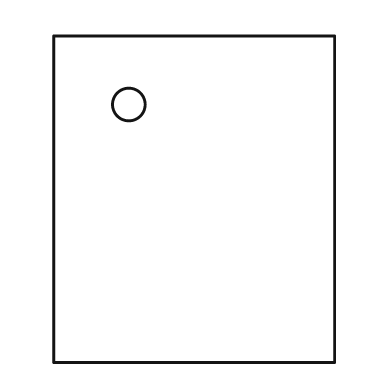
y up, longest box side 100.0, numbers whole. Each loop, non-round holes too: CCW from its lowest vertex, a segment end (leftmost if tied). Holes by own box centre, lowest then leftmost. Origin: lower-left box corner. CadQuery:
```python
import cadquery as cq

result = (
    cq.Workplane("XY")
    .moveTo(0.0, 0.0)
    .lineTo(86.0, 0.0)
    .lineTo(86.0, 100.0)
    .lineTo(0.0, 100.0)
    .close()
    .moveTo(23.0, 79.0)
    .circle(5.0)
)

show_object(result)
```